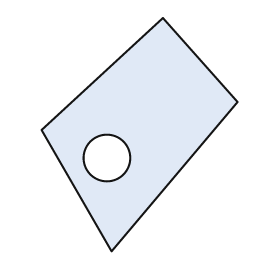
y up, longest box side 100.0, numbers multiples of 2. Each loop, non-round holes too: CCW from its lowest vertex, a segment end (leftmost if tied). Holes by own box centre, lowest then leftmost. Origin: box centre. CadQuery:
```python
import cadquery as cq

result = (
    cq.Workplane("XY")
    .moveTo(-12.0, -50.0)
    .lineTo(42.0, 14.0)
    .lineTo(10.0, 50.0)
    .lineTo(-42.0, 2.0)
    .close()
    .moveTo(-14.0, -10.0)
    .circle(10.0)
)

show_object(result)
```